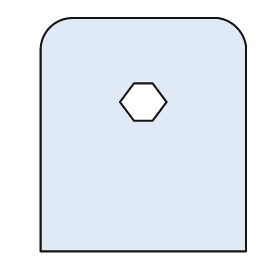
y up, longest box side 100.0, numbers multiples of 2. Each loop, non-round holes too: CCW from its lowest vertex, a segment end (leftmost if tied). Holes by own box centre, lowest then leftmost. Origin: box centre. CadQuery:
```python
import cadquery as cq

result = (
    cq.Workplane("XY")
    .moveTo(-44.0, -50.0)
    .lineTo(44.0, -50.0)
    .lineTo(44.0, 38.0)
    .threePointArc((40.0, 46.0), (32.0, 50.0))
    .lineTo(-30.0, 50.0)
    .threePointArc((-40.0, 46.0), (-44.0, 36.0))
    .close()
    .moveTo(-4.0, 6.0)
    .lineTo(4.0, 6.0)
    .lineTo(10.0, 14.0)
    .lineTo(4.0, 22.0)
    .lineTo(-4.0, 22.0)
    .lineTo(-10.0, 14.0)
    .close()
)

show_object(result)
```